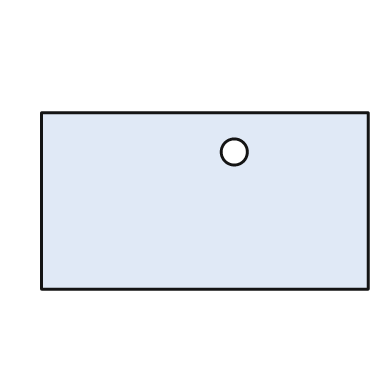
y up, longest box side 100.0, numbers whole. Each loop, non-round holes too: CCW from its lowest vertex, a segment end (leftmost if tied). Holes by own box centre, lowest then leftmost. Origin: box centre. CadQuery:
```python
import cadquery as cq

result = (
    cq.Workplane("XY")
    .moveTo(-50.0, -27.0)
    .lineTo(50.0, -27.0)
    .lineTo(50.0, 27.0)
    .lineTo(-50.0, 27.0)
    .close()
    .moveTo(9.0, 15.0)
    .circle(4.0)
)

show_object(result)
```